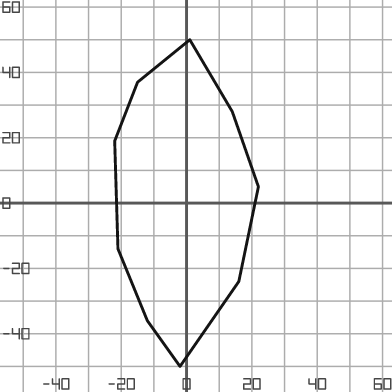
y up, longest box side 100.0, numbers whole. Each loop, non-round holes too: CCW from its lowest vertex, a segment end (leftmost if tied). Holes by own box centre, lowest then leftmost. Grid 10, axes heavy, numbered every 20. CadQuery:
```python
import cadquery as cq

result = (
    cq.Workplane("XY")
    .moveTo(-2.0, -50.0)
    .lineTo(16.0, -24.0)
    .lineTo(22.0, 5.0)
    .lineTo(14.0, 28.0)
    .lineTo(1.0, 50.0)
    .lineTo(-15.0, 37.0)
    .lineTo(-22.0, 19.0)
    .lineTo(-21.0, -14.0)
    .lineTo(-12.0, -36.0)
    .close()
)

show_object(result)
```